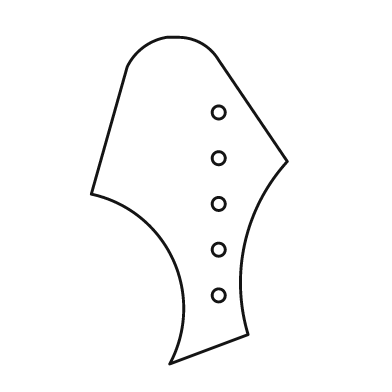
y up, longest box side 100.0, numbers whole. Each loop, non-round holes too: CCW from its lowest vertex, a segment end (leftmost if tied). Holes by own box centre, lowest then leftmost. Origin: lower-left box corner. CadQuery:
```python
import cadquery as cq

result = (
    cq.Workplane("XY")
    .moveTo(24.0, 0.0)
    .lineTo(48.0, 9.0)
    .threePointArc((47.0, 37.0), (60.0, 62.0))
    .lineTo(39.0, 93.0)
    .threePointArc((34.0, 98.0), (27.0, 100.0))
    .lineTo(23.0, 100.0)
    .threePointArc((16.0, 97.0), (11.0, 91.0))
    .lineTo(0.0, 52.0)
    .threePointArc((25.0, 32.0), (24.0, 0.0))
    .close()
    .moveTo(39.0, 21.0)
    .circle(2.0)
    .moveTo(39.0, 35.0)
    .circle(2.0)
    .moveTo(39.0, 49.0)
    .circle(2.0)
    .moveTo(39.0, 63.0)
    .circle(2.0)
    .moveTo(39.0, 77.0)
    .circle(2.0)
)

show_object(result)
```